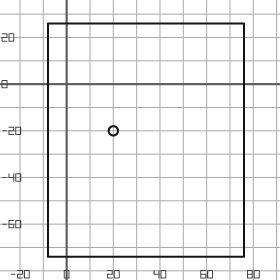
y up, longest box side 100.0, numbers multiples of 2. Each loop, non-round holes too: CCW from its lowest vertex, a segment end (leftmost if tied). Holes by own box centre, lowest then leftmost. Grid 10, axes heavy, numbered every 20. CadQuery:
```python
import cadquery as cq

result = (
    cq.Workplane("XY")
    .moveTo(-8.0, -74.0)
    .lineTo(76.0, -74.0)
    .lineTo(76.0, 26.0)
    .lineTo(-8.0, 26.0)
    .close()
    .moveTo(20.0, -20.0)
    .circle(2.0)
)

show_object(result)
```